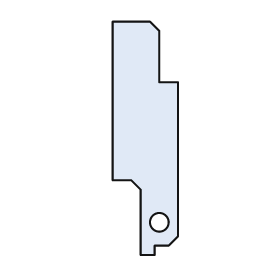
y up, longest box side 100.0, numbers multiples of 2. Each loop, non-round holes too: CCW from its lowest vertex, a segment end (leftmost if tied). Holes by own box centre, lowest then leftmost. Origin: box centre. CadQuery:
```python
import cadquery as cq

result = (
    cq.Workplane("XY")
    .moveTo(-2.0, -50.0)
    .lineTo(4.0, -50.0)
    .lineTo(4.0, -46.0)
    .lineTo(10.0, -46.0)
    .lineTo(14.0, -42.0)
    .lineTo(14.0, 24.0)
    .lineTo(6.0, 24.0)
    .lineTo(6.0, 46.0)
    .lineTo(2.0, 50.0)
    .lineTo(-14.0, 50.0)
    .lineTo(-14.0, -18.0)
    .lineTo(-6.0, -18.0)
    .lineTo(-2.0, -22.0)
    .close()
    .moveTo(6.0, -36.0)
    .circle(4.0)
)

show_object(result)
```